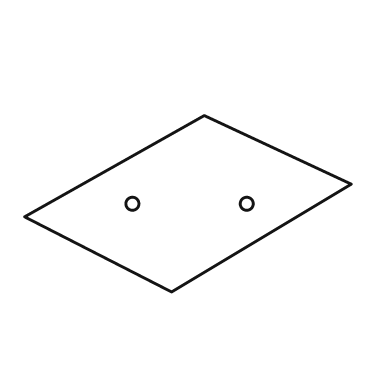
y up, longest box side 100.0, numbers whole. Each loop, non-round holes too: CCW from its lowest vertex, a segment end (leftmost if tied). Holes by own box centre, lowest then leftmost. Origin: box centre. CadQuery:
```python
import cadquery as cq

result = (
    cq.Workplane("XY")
    .moveTo(-5.0, -27.0)
    .lineTo(50.0, 6.0)
    .lineTo(5.0, 27.0)
    .lineTo(-50.0, -4.0)
    .close()
    .moveTo(-17.0, 0.0)
    .circle(2.0)
    .moveTo(18.0, 0.0)
    .circle(2.0)
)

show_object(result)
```